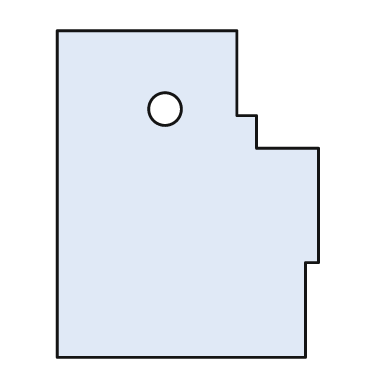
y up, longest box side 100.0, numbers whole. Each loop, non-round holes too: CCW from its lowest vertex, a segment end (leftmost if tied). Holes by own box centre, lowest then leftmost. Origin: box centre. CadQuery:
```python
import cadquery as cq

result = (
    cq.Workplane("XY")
    .moveTo(-40.0, -50.0)
    .lineTo(36.0, -50.0)
    .lineTo(36.0, -21.0)
    .lineTo(40.0, -21.0)
    .lineTo(40.0, 14.0)
    .lineTo(21.0, 14.0)
    .lineTo(21.0, 24.0)
    .lineTo(15.0, 24.0)
    .lineTo(15.0, 50.0)
    .lineTo(-40.0, 50.0)
    .close()
    .moveTo(-7.0, 26.0)
    .circle(5.0)
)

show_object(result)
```